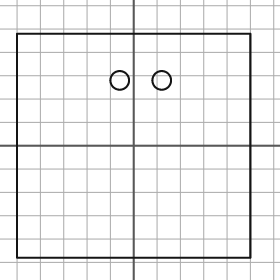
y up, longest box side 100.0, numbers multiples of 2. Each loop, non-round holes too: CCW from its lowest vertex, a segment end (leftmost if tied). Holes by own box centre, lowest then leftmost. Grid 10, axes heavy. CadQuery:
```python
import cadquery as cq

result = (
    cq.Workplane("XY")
    .moveTo(-50.0, -48.0)
    .lineTo(50.0, -48.0)
    .lineTo(50.0, 48.0)
    .lineTo(-50.0, 48.0)
    .close()
    .moveTo(-6.0, 28.0)
    .circle(4.0)
    .moveTo(12.0, 28.0)
    .circle(4.0)
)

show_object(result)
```